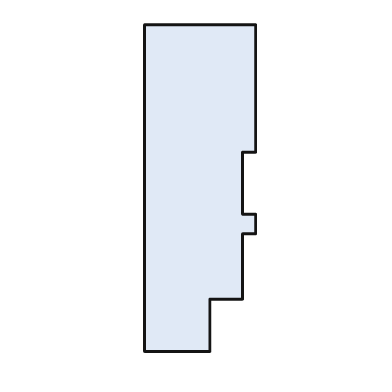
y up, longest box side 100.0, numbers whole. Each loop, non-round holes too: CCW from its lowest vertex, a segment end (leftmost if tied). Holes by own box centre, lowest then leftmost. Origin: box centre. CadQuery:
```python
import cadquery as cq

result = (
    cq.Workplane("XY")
    .moveTo(-17.0, -50.0)
    .lineTo(3.0, -50.0)
    .lineTo(3.0, -34.0)
    .lineTo(13.0, -34.0)
    .lineTo(13.0, -14.0)
    .lineTo(17.0, -14.0)
    .lineTo(17.0, -8.0)
    .lineTo(13.0, -8.0)
    .lineTo(13.0, 11.0)
    .lineTo(17.0, 11.0)
    .lineTo(17.0, 50.0)
    .lineTo(-17.0, 50.0)
    .close()
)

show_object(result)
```